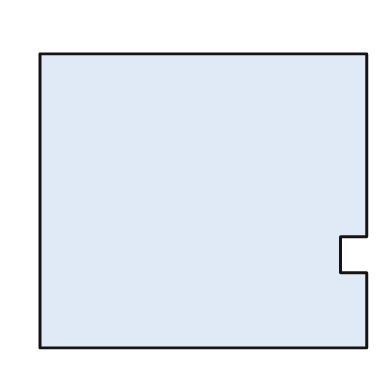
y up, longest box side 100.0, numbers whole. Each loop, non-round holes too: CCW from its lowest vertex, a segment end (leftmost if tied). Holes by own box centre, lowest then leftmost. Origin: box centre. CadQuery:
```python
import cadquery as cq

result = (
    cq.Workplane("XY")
    .moveTo(-50.0, -45.0)
    .lineTo(50.0, -45.0)
    .lineTo(50.0, -22.0)
    .lineTo(42.0, -22.0)
    .lineTo(42.0, -11.0)
    .lineTo(50.0, -11.0)
    .lineTo(50.0, 45.0)
    .lineTo(-50.0, 45.0)
    .close()
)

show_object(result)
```